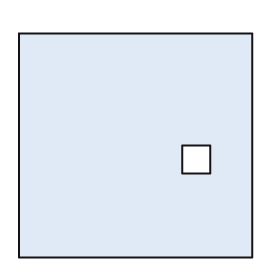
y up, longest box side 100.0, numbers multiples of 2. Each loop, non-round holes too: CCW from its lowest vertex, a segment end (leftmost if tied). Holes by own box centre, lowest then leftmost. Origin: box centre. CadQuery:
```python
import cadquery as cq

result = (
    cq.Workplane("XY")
    .moveTo(-50.0, -48.0)
    .lineTo(50.0, -48.0)
    .lineTo(50.0, 48.0)
    .lineTo(-50.0, 48.0)
    .close()
    .moveTo(20.0, -12.0)
    .lineTo(32.0, -12.0)
    .lineTo(32.0, 0.0)
    .lineTo(20.0, 0.0)
    .close()
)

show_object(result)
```